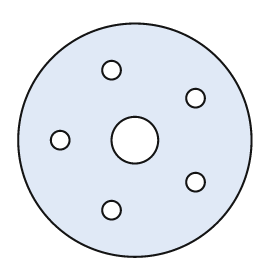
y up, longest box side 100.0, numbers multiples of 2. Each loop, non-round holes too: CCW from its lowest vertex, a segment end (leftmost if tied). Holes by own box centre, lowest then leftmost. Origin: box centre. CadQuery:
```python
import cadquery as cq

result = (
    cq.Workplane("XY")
    .moveTo(0.0, 0.0)
    .circle(50.0)
    .moveTo(-10.0, -30.0)
    .circle(4.0)
    .moveTo(26.0, -18.0)
    .circle(4.0)
    .moveTo(-32.0, 0.0)
    .circle(4.0)
    .moveTo(0.0, 0.0)
    .circle(10.0)
    .moveTo(26.0, 18.0)
    .circle(4.0)
    .moveTo(-10.0, 30.0)
    .circle(4.0)
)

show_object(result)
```